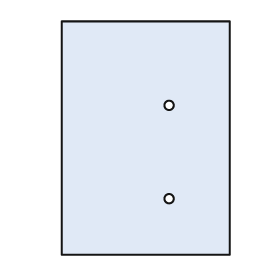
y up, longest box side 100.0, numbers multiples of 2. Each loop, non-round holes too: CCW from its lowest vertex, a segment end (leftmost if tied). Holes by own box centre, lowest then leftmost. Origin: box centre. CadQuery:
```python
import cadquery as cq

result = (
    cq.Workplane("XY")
    .moveTo(-36.0, -50.0)
    .lineTo(36.0, -50.0)
    .lineTo(36.0, 50.0)
    .lineTo(-36.0, 50.0)
    .close()
    .moveTo(10.0, -26.0)
    .circle(2.0)
    .moveTo(10.0, 14.0)
    .circle(2.0)
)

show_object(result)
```